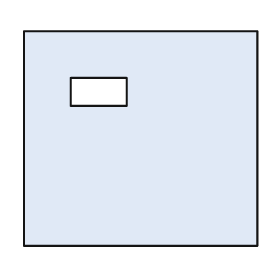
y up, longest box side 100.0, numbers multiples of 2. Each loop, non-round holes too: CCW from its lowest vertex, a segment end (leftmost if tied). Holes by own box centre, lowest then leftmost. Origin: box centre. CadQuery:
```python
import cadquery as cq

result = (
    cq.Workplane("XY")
    .moveTo(-50.0, -46.0)
    .lineTo(50.0, -46.0)
    .lineTo(50.0, 46.0)
    .lineTo(-50.0, 46.0)
    .close()
    .moveTo(-30.0, 14.0)
    .lineTo(-6.0, 14.0)
    .lineTo(-6.0, 26.0)
    .lineTo(-30.0, 26.0)
    .close()
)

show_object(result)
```